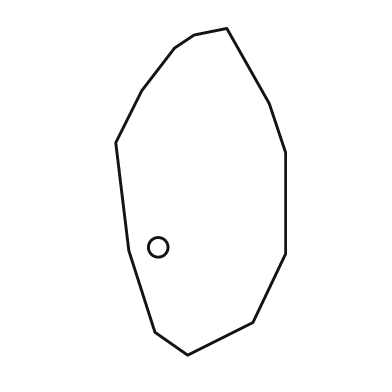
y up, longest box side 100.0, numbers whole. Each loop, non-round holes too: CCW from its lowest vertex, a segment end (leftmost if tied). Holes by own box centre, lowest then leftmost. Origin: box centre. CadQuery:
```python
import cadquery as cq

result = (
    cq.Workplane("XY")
    .moveTo(-4.0, -50.0)
    .lineTo(16.0, -40.0)
    .lineTo(26.0, -19.0)
    .lineTo(26.0, 12.0)
    .lineTo(21.0, 27.0)
    .lineTo(8.0, 50.0)
    .lineTo(-2.0, 48.0)
    .lineTo(-8.0, 44.0)
    .lineTo(-18.0, 31.0)
    .lineTo(-26.0, 15.0)
    .lineTo(-22.0, -18.0)
    .lineTo(-14.0, -43.0)
    .close()
    .moveTo(-13.0, -17.0)
    .circle(3.0)
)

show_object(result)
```